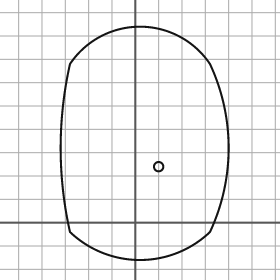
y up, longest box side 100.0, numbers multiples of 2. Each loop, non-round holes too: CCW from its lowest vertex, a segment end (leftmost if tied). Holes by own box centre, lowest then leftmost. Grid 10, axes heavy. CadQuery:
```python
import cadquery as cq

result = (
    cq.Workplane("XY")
    .moveTo(-28.0, -4.0)
    .threePointArc((2.0, -16.0), (32.0, -4.0))
    .threePointArc((40.0, 32.0), (32.0, 68.0))
    .threePointArc((2.0, 84.0), (-28.0, 68.0))
    .threePointArc((-32.0, 32.0), (-28.0, -4.0))
    .close()
    .moveTo(10.0, 24.0)
    .circle(2.0)
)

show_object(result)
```